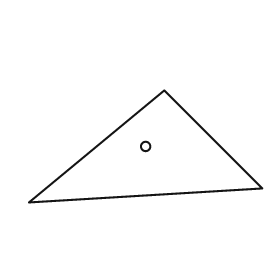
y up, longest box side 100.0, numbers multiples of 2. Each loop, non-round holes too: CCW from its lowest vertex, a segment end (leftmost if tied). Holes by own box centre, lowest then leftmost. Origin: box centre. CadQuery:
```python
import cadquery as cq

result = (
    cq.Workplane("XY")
    .moveTo(-50.0, -24.0)
    .lineTo(50.0, -18.0)
    .lineTo(8.0, 24.0)
    .close()
    .moveTo(0.0, 0.0)
    .circle(2.0)
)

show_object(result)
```